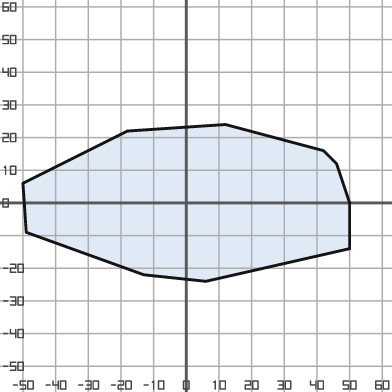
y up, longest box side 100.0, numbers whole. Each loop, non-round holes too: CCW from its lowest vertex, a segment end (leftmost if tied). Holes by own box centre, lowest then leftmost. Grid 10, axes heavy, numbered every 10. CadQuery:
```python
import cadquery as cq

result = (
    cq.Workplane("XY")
    .moveTo(6.0, -24.0)
    .lineTo(50.0, -14.0)
    .lineTo(50.0, 0.0)
    .lineTo(46.0, 12.0)
    .lineTo(42.0, 16.0)
    .lineTo(12.0, 24.0)
    .lineTo(-18.0, 22.0)
    .lineTo(-50.0, 6.0)
    .lineTo(-49.0, -9.0)
    .lineTo(-13.0, -22.0)
    .close()
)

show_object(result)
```